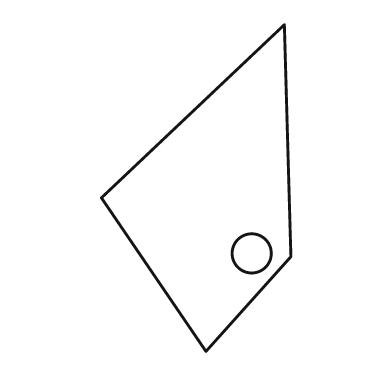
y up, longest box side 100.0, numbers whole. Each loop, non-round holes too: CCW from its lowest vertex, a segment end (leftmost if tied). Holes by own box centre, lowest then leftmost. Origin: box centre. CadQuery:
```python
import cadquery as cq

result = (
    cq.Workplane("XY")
    .moveTo(3.0, -50.0)
    .lineTo(29.0, -21.0)
    .lineTo(27.0, 50.0)
    .lineTo(-29.0, -3.0)
    .close()
    .moveTo(17.0, -20.0)
    .circle(6.0)
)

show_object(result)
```